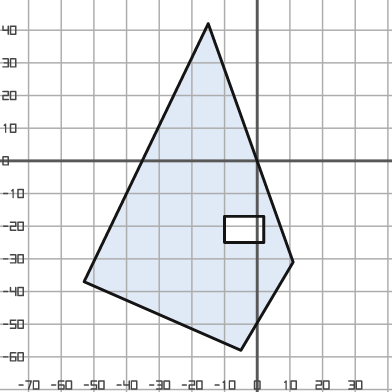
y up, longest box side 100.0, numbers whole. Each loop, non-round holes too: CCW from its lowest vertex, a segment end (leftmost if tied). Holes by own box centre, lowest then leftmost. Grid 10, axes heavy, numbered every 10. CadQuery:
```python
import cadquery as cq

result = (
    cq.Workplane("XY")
    .moveTo(-5.0, -58.0)
    .lineTo(11.0, -31.0)
    .lineTo(-15.0, 42.0)
    .lineTo(-53.0, -37.0)
    .close()
    .moveTo(-10.0, -25.0)
    .lineTo(2.0, -25.0)
    .lineTo(2.0, -17.0)
    .lineTo(-10.0, -17.0)
    .close()
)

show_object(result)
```